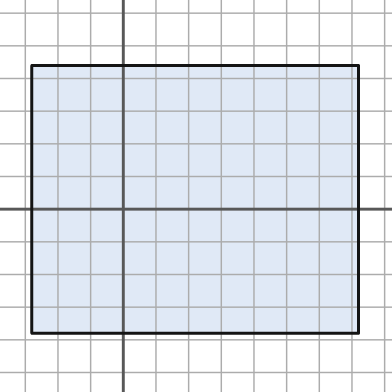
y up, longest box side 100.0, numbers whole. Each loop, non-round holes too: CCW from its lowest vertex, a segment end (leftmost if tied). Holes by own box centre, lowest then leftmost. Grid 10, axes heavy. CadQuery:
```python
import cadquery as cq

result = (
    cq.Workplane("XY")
    .moveTo(-28.0, -38.0)
    .lineTo(72.0, -38.0)
    .lineTo(72.0, 44.0)
    .lineTo(-28.0, 44.0)
    .close()
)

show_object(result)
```